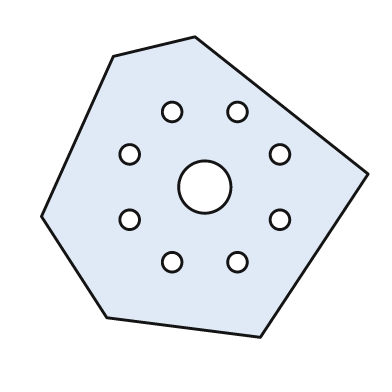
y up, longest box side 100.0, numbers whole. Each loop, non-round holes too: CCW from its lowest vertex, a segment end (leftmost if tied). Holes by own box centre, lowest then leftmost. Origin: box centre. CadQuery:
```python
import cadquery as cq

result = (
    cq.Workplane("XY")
    .moveTo(17.0, -46.0)
    .lineTo(50.0, 4.0)
    .lineTo(-3.0, 46.0)
    .lineTo(-28.0, 40.0)
    .lineTo(-50.0, -9.0)
    .lineTo(-30.0, -40.0)
    .close()
    .moveTo(-10.0, -23.0)
    .circle(3.0)
    .moveTo(10.0, -23.0)
    .circle(3.0)
    .moveTo(-23.0, -10.0)
    .circle(3.0)
    .moveTo(23.0, -10.0)
    .circle(3.0)
    .moveTo(0.0, 0.0)
    .circle(8.0)
    .moveTo(-23.0, 10.0)
    .circle(3.0)
    .moveTo(23.0, 10.0)
    .circle(3.0)
    .moveTo(-10.0, 23.0)
    .circle(3.0)
    .moveTo(10.0, 23.0)
    .circle(3.0)
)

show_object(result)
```